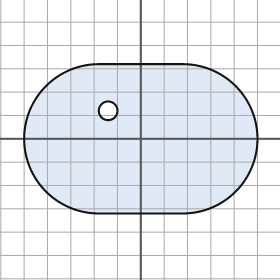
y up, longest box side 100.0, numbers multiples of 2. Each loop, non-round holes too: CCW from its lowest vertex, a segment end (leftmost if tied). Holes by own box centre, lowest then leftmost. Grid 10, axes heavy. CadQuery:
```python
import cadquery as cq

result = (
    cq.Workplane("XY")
    .moveTo(-18.0, -32.0)
    .lineTo(18.0, -32.0)
    .threePointArc((50.0, 0.0), (18.0, 32.0))
    .lineTo(-18.0, 32.0)
    .threePointArc((-50.0, 0.0), (-18.0, -32.0))
    .close()
    .moveTo(-14.0, 12.0)
    .circle(4.0)
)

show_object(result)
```